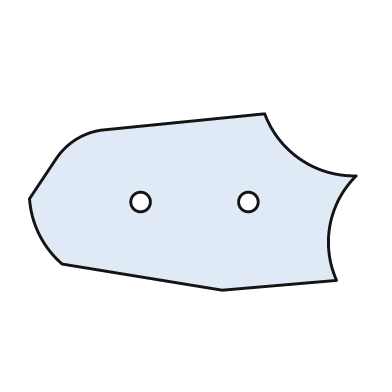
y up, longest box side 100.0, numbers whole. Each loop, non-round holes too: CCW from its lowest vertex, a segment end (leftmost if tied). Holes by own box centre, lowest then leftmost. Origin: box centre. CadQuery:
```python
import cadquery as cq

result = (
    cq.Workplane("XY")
    .moveTo(9.0, -27.0)
    .lineTo(44.0, -24.0)
    .threePointArc((42.0, -7.0), (50.0, 8.0))
    .threePointArc((33.0, 13.0), (22.0, 27.0))
    .lineTo(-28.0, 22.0)
    .threePointArc((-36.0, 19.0), (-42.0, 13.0))
    .lineTo(-50.0, 1.0)
    .threePointArc((-47.0, -10.0), (-40.0, -19.0))
    .close()
    .moveTo(-16.0, 0.0)
    .circle(3.0)
    .moveTo(17.0, 0.0)
    .circle(3.0)
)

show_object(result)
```